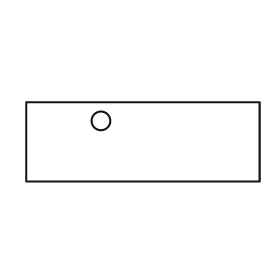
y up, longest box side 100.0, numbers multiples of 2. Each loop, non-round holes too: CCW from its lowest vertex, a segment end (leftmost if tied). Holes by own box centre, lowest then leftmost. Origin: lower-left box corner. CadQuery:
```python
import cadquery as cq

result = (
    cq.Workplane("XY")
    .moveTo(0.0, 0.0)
    .lineTo(100.0, 0.0)
    .lineTo(100.0, 34.0)
    .lineTo(0.0, 34.0)
    .close()
    .moveTo(32.0, 26.0)
    .circle(4.0)
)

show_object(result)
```